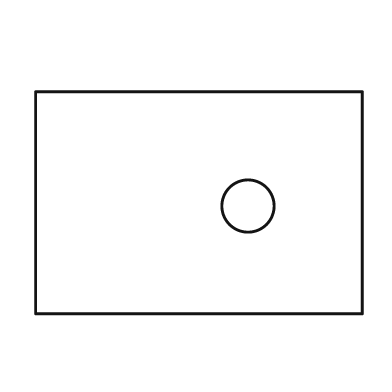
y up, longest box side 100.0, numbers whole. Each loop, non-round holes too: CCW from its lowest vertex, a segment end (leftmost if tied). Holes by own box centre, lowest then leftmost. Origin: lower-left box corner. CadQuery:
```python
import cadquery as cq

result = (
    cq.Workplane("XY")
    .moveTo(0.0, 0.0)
    .lineTo(100.0, 0.0)
    .lineTo(100.0, 68.0)
    .lineTo(0.0, 68.0)
    .close()
    .moveTo(65.0, 33.0)
    .circle(8.0)
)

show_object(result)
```